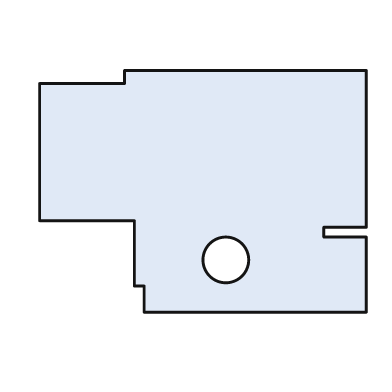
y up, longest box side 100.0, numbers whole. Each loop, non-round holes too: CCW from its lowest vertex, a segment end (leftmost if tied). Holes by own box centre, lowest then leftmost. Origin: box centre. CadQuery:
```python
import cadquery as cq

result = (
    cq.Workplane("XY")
    .moveTo(-18.0, -37.0)
    .lineTo(50.0, -37.0)
    .lineTo(50.0, -14.0)
    .lineTo(37.0, -14.0)
    .lineTo(37.0, -11.0)
    .lineTo(50.0, -11.0)
    .lineTo(50.0, 37.0)
    .lineTo(-24.0, 37.0)
    .lineTo(-24.0, 33.0)
    .lineTo(-50.0, 33.0)
    .lineTo(-50.0, -9.0)
    .lineTo(-21.0, -9.0)
    .lineTo(-21.0, -29.0)
    .lineTo(-18.0, -29.0)
    .close()
    .moveTo(7.0, -21.0)
    .circle(7.0)
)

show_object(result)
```